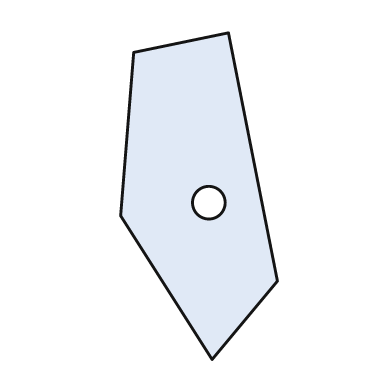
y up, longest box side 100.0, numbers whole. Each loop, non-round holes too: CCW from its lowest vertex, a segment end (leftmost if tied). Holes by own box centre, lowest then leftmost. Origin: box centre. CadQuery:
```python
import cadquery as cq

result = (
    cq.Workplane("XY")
    .moveTo(4.0, -50.0)
    .lineTo(24.0, -26.0)
    .lineTo(9.0, 50.0)
    .lineTo(-20.0, 44.0)
    .lineTo(-24.0, -6.0)
    .close()
    .moveTo(3.0, -2.0)
    .circle(5.0)
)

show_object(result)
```